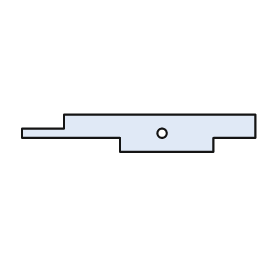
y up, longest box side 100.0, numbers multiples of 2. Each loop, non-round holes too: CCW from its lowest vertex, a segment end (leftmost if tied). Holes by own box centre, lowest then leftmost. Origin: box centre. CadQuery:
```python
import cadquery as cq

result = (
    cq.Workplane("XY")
    .moveTo(-8.0, -8.0)
    .lineTo(32.0, -8.0)
    .lineTo(32.0, -2.0)
    .lineTo(50.0, -2.0)
    .lineTo(50.0, 8.0)
    .lineTo(-32.0, 8.0)
    .lineTo(-32.0, 2.0)
    .lineTo(-50.0, 2.0)
    .lineTo(-50.0, -2.0)
    .lineTo(-8.0, -2.0)
    .close()
    .moveTo(10.0, 0.0)
    .circle(2.0)
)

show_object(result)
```